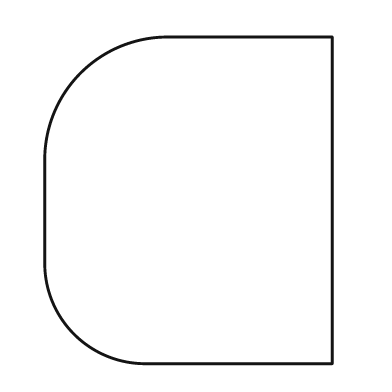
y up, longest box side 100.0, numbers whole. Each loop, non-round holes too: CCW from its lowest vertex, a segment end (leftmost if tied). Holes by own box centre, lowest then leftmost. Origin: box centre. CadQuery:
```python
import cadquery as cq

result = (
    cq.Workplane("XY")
    .moveTo(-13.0, -50.0)
    .lineTo(44.0, -50.0)
    .lineTo(44.0, 50.0)
    .lineTo(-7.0, 50.0)
    .threePointArc((-33.0, 39.0), (-44.0, 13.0))
    .lineTo(-44.0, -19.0)
    .threePointArc((-35.0, -41.0), (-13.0, -50.0))
    .close()
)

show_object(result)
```